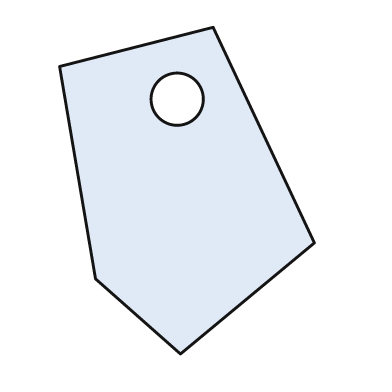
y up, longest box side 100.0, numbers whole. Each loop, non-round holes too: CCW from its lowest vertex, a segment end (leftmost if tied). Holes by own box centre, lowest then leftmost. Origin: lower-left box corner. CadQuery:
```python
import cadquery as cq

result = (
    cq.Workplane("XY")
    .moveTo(37.0, 0.0)
    .lineTo(78.0, 34.0)
    .lineTo(47.0, 100.0)
    .lineTo(0.0, 88.0)
    .lineTo(11.0, 23.0)
    .close()
    .moveTo(36.0, 78.0)
    .circle(8.0)
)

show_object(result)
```